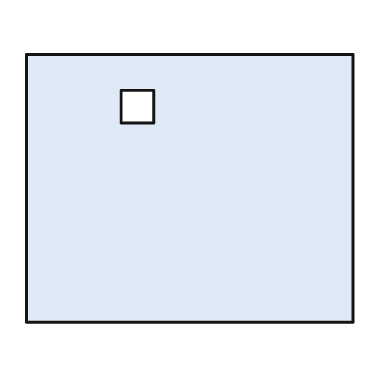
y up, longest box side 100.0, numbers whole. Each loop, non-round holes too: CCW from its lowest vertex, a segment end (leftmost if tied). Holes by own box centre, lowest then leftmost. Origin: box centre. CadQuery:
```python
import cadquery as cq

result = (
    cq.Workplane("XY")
    .moveTo(-50.0, -41.0)
    .lineTo(50.0, -41.0)
    .lineTo(50.0, 41.0)
    .lineTo(-50.0, 41.0)
    .close()
    .moveTo(-21.0, 20.0)
    .lineTo(-11.0, 20.0)
    .lineTo(-11.0, 30.0)
    .lineTo(-21.0, 30.0)
    .close()
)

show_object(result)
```